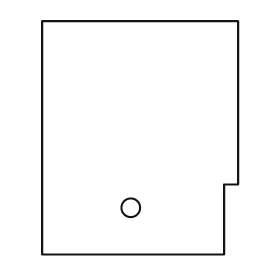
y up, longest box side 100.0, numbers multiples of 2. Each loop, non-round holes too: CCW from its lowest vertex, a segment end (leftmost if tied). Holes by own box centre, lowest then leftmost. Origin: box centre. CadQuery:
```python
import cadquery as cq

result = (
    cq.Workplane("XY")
    .moveTo(-42.0, -50.0)
    .lineTo(36.0, -50.0)
    .lineTo(36.0, -20.0)
    .lineTo(42.0, -20.0)
    .lineTo(42.0, 50.0)
    .lineTo(-42.0, 50.0)
    .close()
    .moveTo(-4.0, -30.0)
    .circle(4.0)
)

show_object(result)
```